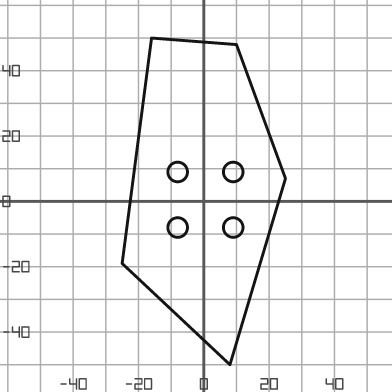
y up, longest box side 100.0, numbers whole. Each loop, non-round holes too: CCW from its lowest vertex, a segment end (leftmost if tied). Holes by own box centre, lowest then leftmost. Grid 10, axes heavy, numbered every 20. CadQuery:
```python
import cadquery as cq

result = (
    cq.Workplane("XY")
    .moveTo(8.0, -50.0)
    .lineTo(25.0, 7.0)
    .lineTo(10.0, 48.0)
    .lineTo(-16.0, 50.0)
    .lineTo(-25.0, -19.0)
    .close()
    .moveTo(-8.0, -8.0)
    .circle(3.0)
    .moveTo(9.0, -8.0)
    .circle(3.0)
    .moveTo(-8.0, 9.0)
    .circle(3.0)
    .moveTo(9.0, 9.0)
    .circle(3.0)
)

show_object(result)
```